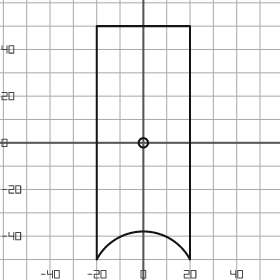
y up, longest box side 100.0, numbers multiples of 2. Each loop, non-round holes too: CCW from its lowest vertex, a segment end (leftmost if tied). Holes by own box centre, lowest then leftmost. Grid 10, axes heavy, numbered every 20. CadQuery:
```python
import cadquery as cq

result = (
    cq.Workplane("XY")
    .moveTo(-20.0, -50.0)
    .threePointArc((0.0, -38.0), (20.0, -50.0))
    .lineTo(20.0, 50.0)
    .lineTo(-20.0, 50.0)
    .close()
    .moveTo(0.0, 0.0)
    .circle(2.0)
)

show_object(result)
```